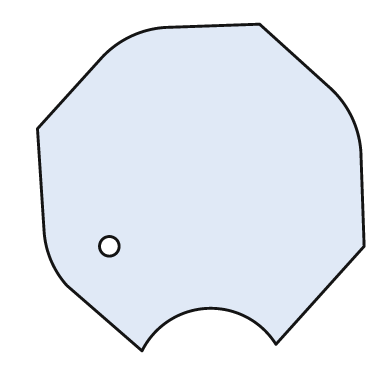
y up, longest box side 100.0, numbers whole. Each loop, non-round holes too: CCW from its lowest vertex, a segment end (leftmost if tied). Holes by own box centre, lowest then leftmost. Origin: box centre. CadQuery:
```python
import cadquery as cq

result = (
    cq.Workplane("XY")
    .moveTo(-18.0, -50.0)
    .threePointArc((2.0, -37.0), (23.0, -48.0))
    .lineTo(50.0, -18.0)
    .lineTo(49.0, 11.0)
    .threePointArc((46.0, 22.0), (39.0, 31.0))
    .lineTo(18.0, 50.0)
    .lineTo(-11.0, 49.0)
    .threePointArc((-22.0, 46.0), (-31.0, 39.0))
    .lineTo(-50.0, 18.0)
    .lineTo(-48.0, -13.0)
    .threePointArc((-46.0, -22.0), (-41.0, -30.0))
    .close()
    .moveTo(-28.0, -18.0)
    .circle(3.0)
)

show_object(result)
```